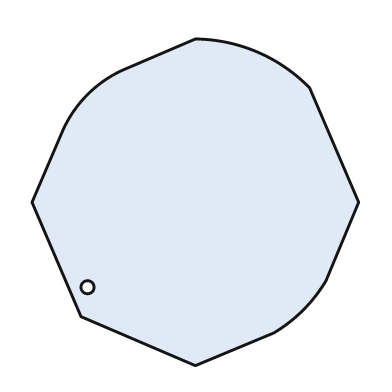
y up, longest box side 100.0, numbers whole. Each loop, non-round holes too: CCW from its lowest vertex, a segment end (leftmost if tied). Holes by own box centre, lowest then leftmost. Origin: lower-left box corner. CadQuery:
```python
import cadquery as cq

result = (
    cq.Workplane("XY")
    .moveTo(50.0, 0.0)
    .lineTo(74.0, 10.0)
    .threePointArc((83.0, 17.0), (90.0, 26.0))
    .lineTo(100.0, 50.0)
    .lineTo(85.0, 85.0)
    .threePointArc((69.0, 96.0), (50.0, 100.0))
    .lineTo(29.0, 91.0)
    .threePointArc((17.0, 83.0), (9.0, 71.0))
    .lineTo(0.0, 50.0)
    .lineTo(15.0, 15.0)
    .close()
    .moveTo(17.0, 24.0)
    .circle(2.0)
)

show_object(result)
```